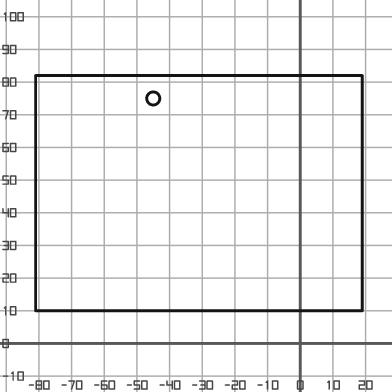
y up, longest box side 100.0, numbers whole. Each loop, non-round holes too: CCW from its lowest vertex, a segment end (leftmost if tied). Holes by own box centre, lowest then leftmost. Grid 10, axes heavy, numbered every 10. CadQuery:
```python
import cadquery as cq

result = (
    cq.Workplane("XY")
    .moveTo(-81.0, 10.0)
    .lineTo(19.0, 10.0)
    .lineTo(19.0, 82.0)
    .lineTo(-81.0, 82.0)
    .close()
    .moveTo(-45.0, 75.0)
    .circle(2.0)
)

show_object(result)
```